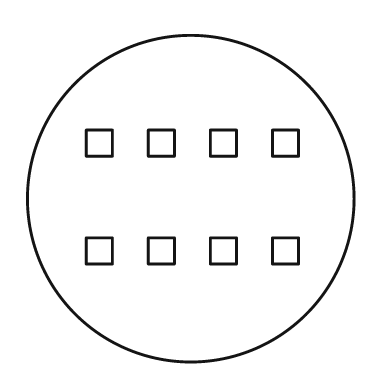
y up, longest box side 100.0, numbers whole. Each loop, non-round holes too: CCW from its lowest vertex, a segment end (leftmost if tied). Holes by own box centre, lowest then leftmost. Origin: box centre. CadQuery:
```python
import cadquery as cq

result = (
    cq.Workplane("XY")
    .moveTo(0.0, 0.0)
    .circle(50.0)
    .moveTo(-32.0, -20.0)
    .lineTo(-24.0, -20.0)
    .lineTo(-24.0, -12.0)
    .lineTo(-32.0, -12.0)
    .close()
    .moveTo(-13.0, -20.0)
    .lineTo(-5.0, -20.0)
    .lineTo(-5.0, -12.0)
    .lineTo(-13.0, -12.0)
    .close()
    .moveTo(6.0, -20.0)
    .lineTo(14.0, -20.0)
    .lineTo(14.0, -12.0)
    .lineTo(6.0, -12.0)
    .close()
    .moveTo(25.0, -20.0)
    .lineTo(33.0, -20.0)
    .lineTo(33.0, -12.0)
    .lineTo(25.0, -12.0)
    .close()
    .moveTo(-32.0, 13.0)
    .lineTo(-24.0, 13.0)
    .lineTo(-24.0, 21.0)
    .lineTo(-32.0, 21.0)
    .close()
    .moveTo(-13.0, 13.0)
    .lineTo(-5.0, 13.0)
    .lineTo(-5.0, 21.0)
    .lineTo(-13.0, 21.0)
    .close()
    .moveTo(6.0, 13.0)
    .lineTo(14.0, 13.0)
    .lineTo(14.0, 21.0)
    .lineTo(6.0, 21.0)
    .close()
    .moveTo(25.0, 13.0)
    .lineTo(33.0, 13.0)
    .lineTo(33.0, 21.0)
    .lineTo(25.0, 21.0)
    .close()
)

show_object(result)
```